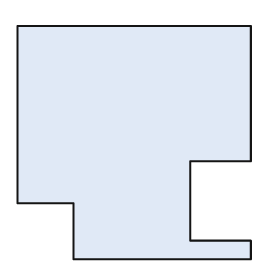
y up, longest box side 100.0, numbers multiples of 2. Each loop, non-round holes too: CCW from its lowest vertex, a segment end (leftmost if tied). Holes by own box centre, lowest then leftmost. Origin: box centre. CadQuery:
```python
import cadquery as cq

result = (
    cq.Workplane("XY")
    .moveTo(-26.0, -50.0)
    .lineTo(50.0, -50.0)
    .lineTo(50.0, -42.0)
    .lineTo(24.0, -42.0)
    .lineTo(24.0, -8.0)
    .lineTo(50.0, -8.0)
    .lineTo(50.0, 50.0)
    .lineTo(-50.0, 50.0)
    .lineTo(-50.0, -26.0)
    .lineTo(-26.0, -26.0)
    .close()
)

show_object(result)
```